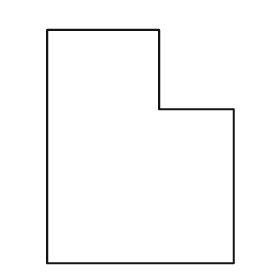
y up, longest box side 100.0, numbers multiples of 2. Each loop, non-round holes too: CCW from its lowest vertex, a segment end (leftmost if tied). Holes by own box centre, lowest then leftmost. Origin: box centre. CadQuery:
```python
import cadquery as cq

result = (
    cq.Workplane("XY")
    .moveTo(-40.0, -50.0)
    .lineTo(40.0, -50.0)
    .lineTo(40.0, 16.0)
    .lineTo(8.0, 16.0)
    .lineTo(8.0, 50.0)
    .lineTo(-40.0, 50.0)
    .close()
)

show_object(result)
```